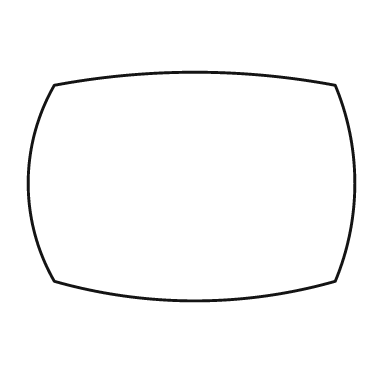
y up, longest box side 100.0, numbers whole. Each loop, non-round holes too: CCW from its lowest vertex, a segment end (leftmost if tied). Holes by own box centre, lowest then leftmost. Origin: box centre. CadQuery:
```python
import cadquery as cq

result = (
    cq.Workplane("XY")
    .moveTo(-42.0, -29.0)
    .threePointArc((1.0, -35.0), (44.0, -29.0))
    .threePointArc((50.0, 1.0), (44.0, 31.0))
    .threePointArc((1.0, 35.0), (-42.0, 31.0))
    .threePointArc((-50.0, 1.0), (-42.0, -29.0))
    .close()
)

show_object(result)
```